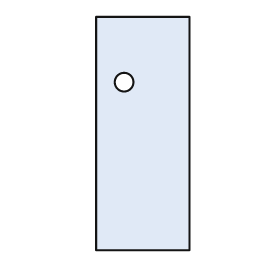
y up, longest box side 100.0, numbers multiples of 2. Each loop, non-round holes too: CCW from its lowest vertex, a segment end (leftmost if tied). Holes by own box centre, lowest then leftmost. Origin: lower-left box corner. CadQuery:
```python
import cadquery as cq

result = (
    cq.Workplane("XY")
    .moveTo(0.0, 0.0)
    .lineTo(40.0, 0.0)
    .lineTo(40.0, 100.0)
    .lineTo(0.0, 100.0)
    .close()
    .moveTo(12.0, 72.0)
    .circle(4.0)
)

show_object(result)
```